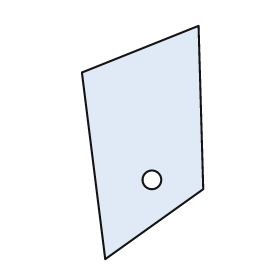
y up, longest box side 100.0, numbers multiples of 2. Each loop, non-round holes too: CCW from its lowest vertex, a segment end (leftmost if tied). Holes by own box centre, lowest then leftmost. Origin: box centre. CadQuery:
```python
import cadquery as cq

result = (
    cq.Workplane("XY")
    .moveTo(-16.0, -50.0)
    .lineTo(26.0, -20.0)
    .lineTo(24.0, 50.0)
    .lineTo(-26.0, 30.0)
    .close()
    .moveTo(4.0, -16.0)
    .circle(4.0)
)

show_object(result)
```